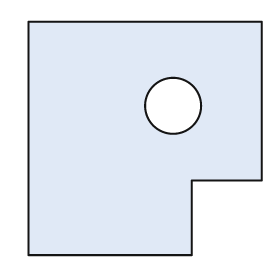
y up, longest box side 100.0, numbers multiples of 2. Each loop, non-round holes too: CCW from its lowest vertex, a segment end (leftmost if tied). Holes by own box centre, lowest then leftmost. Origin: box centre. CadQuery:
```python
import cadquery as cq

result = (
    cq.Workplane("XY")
    .moveTo(-50.0, -50.0)
    .lineTo(20.0, -50.0)
    .lineTo(20.0, -18.0)
    .lineTo(50.0, -18.0)
    .lineTo(50.0, 50.0)
    .lineTo(-50.0, 50.0)
    .close()
    .moveTo(12.0, 14.0)
    .circle(12.0)
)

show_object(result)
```